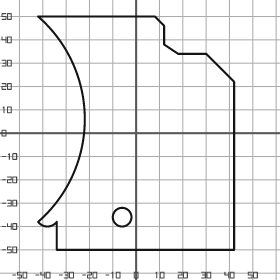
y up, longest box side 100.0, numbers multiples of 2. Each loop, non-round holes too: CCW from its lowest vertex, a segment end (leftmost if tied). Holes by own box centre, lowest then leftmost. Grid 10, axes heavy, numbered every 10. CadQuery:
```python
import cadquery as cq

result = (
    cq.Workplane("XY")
    .moveTo(-34.0, -50.0)
    .lineTo(42.0, -50.0)
    .lineTo(42.0, 22.0)
    .lineTo(30.0, 34.0)
    .lineTo(18.0, 34.0)
    .lineTo(12.0, 38.0)
    .lineTo(12.0, 46.0)
    .lineTo(8.0, 50.0)
    .lineTo(-42.0, 50.0)
    .threePointArc((-22.0, 6.0), (-42.0, -38.0))
    .threePointArc((-38.0, -40.0), (-34.0, -38.0))
    .close()
    .moveTo(-6.0, -36.0)
    .circle(4.0)
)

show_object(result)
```